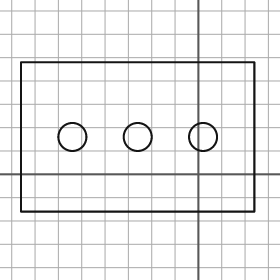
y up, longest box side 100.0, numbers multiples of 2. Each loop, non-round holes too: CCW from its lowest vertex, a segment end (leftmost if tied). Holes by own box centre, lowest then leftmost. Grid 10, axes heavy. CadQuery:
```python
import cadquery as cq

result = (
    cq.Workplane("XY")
    .moveTo(-76.0, -16.0)
    .lineTo(24.0, -16.0)
    .lineTo(24.0, 48.0)
    .lineTo(-76.0, 48.0)
    .close()
    .moveTo(-54.0, 16.0)
    .circle(6.0)
    .moveTo(-26.0, 16.0)
    .circle(6.0)
    .moveTo(2.0, 16.0)
    .circle(6.0)
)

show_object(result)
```